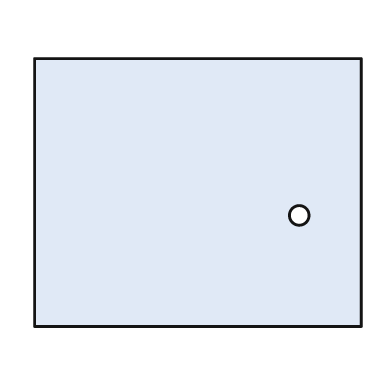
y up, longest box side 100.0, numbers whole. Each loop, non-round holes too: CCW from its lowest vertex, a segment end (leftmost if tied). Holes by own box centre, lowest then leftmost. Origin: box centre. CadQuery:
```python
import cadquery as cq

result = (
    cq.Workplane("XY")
    .moveTo(-50.0, -41.0)
    .lineTo(50.0, -41.0)
    .lineTo(50.0, 41.0)
    .lineTo(-50.0, 41.0)
    .close()
    .moveTo(31.0, -7.0)
    .circle(3.0)
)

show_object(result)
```